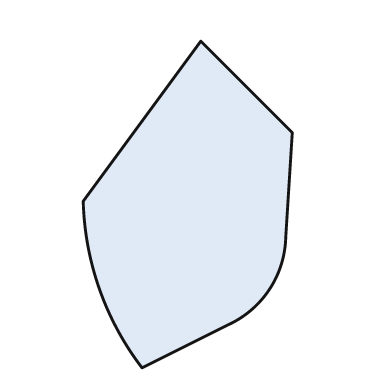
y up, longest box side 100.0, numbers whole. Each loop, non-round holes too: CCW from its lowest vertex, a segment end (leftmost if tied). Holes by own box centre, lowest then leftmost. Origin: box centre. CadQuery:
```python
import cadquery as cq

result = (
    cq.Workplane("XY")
    .moveTo(-14.0, -50.0)
    .lineTo(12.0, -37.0)
    .threePointArc((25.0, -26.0), (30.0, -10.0))
    .lineTo(32.0, 22.0)
    .lineTo(4.0, 50.0)
    .lineTo(-32.0, 1.0)
    .threePointArc((-27.0, -26.0), (-14.0, -50.0))
    .close()
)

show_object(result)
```